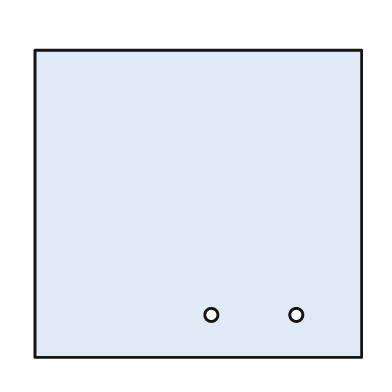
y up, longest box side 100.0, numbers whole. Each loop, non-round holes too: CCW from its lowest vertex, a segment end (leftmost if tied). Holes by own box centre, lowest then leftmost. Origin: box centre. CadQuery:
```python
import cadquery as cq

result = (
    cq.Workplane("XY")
    .moveTo(-50.0, -47.0)
    .lineTo(50.0, -47.0)
    .lineTo(50.0, 47.0)
    .lineTo(-50.0, 47.0)
    .close()
    .moveTo(4.0, -34.0)
    .circle(2.0)
    .moveTo(30.0, -34.0)
    .circle(2.0)
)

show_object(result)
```